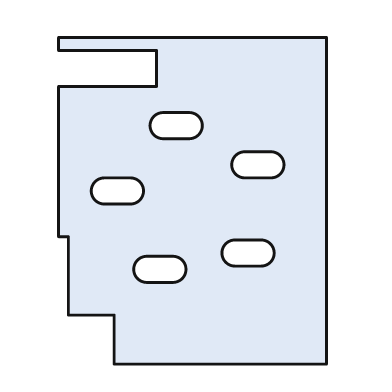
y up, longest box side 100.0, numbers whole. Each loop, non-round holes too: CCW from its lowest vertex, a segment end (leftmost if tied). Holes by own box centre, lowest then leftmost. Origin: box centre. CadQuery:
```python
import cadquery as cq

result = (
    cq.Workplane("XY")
    .moveTo(-24.0, -50.0)
    .lineTo(41.0, -50.0)
    .lineTo(41.0, 50.0)
    .lineTo(-41.0, 50.0)
    .lineTo(-41.0, 46.0)
    .lineTo(-11.0, 46.0)
    .lineTo(-11.0, 35.0)
    .lineTo(-41.0, 35.0)
    .lineTo(-41.0, -11.0)
    .lineTo(-38.0, -11.0)
    .lineTo(-38.0, -35.0)
    .lineTo(-24.0, -35.0)
    .close()
    .moveTo(-14.0, -25.0)
    .lineTo(-6.0, -25.0)
    .threePointArc((-2.0, -21.0), (-6.0, -17.0))
    .lineTo(-14.0, -17.0)
    .threePointArc((-18.0, -21.0), (-14.0, -25.0))
    .close()
    .moveTo(13.0, -20.0)
    .lineTo(21.0, -20.0)
    .threePointArc((25.0, -16.0), (21.0, -12.0))
    .lineTo(13.0, -12.0)
    .threePointArc((9.0, -16.0), (13.0, -20.0))
    .close()
    .moveTo(-27.0, -1.0)
    .lineTo(-19.0, -1.0)
    .threePointArc((-15.0, 3.0), (-19.0, 7.0))
    .lineTo(-27.0, 7.0)
    .threePointArc((-31.0, 3.0), (-27.0, -1.0))
    .close()
    .moveTo(16.0, 7.0)
    .lineTo(24.0, 7.0)
    .threePointArc((28.0, 11.0), (24.0, 15.0))
    .lineTo(16.0, 15.0)
    .threePointArc((12.0, 11.0), (16.0, 7.0))
    .close()
    .moveTo(-9.0, 19.0)
    .lineTo(-1.0, 19.0)
    .threePointArc((3.0, 23.0), (-1.0, 27.0))
    .lineTo(-9.0, 27.0)
    .threePointArc((-13.0, 23.0), (-9.0, 19.0))
    .close()
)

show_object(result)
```